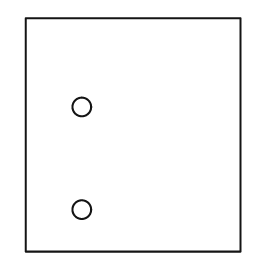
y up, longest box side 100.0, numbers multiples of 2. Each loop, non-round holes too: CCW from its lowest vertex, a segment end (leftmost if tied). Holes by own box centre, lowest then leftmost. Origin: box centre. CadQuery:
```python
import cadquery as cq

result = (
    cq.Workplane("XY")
    .moveTo(-46.0, -50.0)
    .lineTo(46.0, -50.0)
    .lineTo(46.0, 50.0)
    .lineTo(-46.0, 50.0)
    .close()
    .moveTo(-22.0, -32.0)
    .circle(4.0)
    .moveTo(-22.0, 12.0)
    .circle(4.0)
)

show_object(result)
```